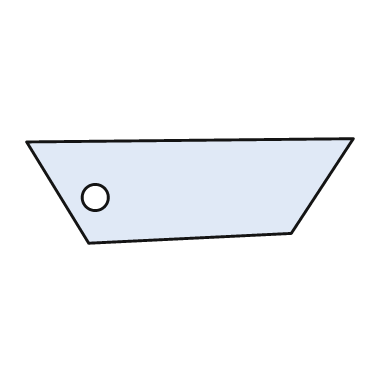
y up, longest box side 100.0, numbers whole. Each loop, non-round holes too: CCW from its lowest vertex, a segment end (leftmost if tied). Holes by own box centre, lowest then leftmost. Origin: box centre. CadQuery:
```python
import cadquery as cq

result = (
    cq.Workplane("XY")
    .moveTo(-31.0, -16.0)
    .lineTo(31.0, -13.0)
    .lineTo(50.0, 16.0)
    .lineTo(-50.0, 15.0)
    .close()
    .moveTo(-29.0, -2.0)
    .circle(4.0)
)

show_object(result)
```